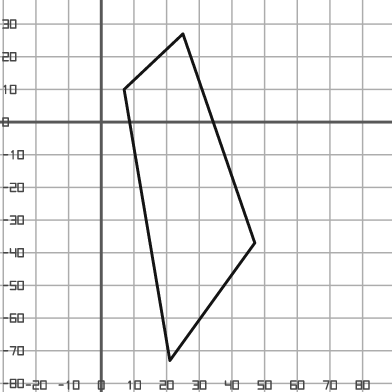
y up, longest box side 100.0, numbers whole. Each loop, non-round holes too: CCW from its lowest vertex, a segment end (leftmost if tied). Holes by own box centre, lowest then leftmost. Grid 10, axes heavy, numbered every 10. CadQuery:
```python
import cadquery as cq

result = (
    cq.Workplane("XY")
    .moveTo(21.0, -73.0)
    .lineTo(47.0, -37.0)
    .lineTo(25.0, 27.0)
    .lineTo(7.0, 10.0)
    .close()
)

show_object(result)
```